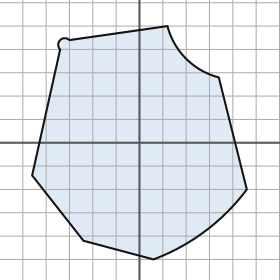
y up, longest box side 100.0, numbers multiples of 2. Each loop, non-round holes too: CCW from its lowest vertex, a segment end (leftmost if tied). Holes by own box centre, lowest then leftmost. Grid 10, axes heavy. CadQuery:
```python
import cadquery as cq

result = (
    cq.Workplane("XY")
    .moveTo(6.0, -50.0)
    .threePointArc((28.0, -38.0), (46.0, -20.0))
    .lineTo(34.0, 28.0)
    .threePointArc((20.0, 36.0), (12.0, 50.0))
    .lineTo(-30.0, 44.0)
    .threePointArc((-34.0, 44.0), (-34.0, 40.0))
    .lineTo(-46.0, -14.0)
    .lineTo(-24.0, -42.0)
    .close()
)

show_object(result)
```